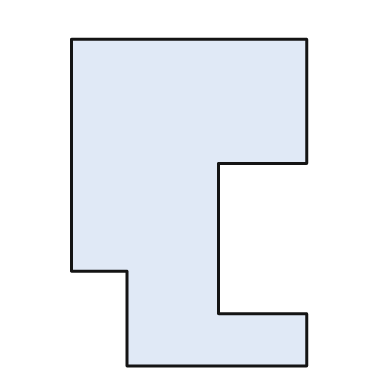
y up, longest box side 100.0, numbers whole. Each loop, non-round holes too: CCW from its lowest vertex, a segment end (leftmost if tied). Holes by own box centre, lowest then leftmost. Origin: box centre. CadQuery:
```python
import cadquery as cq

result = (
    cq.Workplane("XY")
    .moveTo(-19.0, -50.0)
    .lineTo(36.0, -50.0)
    .lineTo(36.0, -34.0)
    .lineTo(9.0, -34.0)
    .lineTo(9.0, 12.0)
    .lineTo(36.0, 12.0)
    .lineTo(36.0, 50.0)
    .lineTo(-36.0, 50.0)
    .lineTo(-36.0, -21.0)
    .lineTo(-19.0, -21.0)
    .close()
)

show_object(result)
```